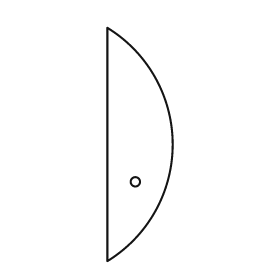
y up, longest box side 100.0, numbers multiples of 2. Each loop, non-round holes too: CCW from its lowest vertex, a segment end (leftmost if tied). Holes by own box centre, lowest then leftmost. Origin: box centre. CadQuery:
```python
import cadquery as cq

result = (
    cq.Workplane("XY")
    .moveTo(-14.0, -50.0)
    .threePointArc((14.0, 0.0), (-14.0, 50.0))
    .close()
    .moveTo(-2.0, -16.0)
    .circle(2.0)
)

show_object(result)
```